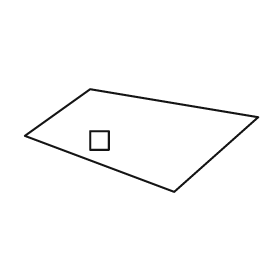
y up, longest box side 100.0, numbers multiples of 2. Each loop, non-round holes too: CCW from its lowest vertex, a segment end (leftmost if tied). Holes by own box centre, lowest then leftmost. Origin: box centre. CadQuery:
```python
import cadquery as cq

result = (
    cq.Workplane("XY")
    .moveTo(14.0, -22.0)
    .lineTo(50.0, 10.0)
    .lineTo(-22.0, 22.0)
    .lineTo(-50.0, 2.0)
    .close()
    .moveTo(-22.0, -4.0)
    .lineTo(-14.0, -4.0)
    .lineTo(-14.0, 4.0)
    .lineTo(-22.0, 4.0)
    .close()
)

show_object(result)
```